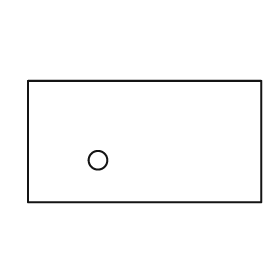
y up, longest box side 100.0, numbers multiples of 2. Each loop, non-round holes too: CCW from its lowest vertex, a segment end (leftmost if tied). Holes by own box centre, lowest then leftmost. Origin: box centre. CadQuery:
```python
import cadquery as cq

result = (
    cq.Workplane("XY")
    .moveTo(-50.0, -26.0)
    .lineTo(50.0, -26.0)
    .lineTo(50.0, 26.0)
    .lineTo(-50.0, 26.0)
    .close()
    .moveTo(-20.0, -8.0)
    .circle(4.0)
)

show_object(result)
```